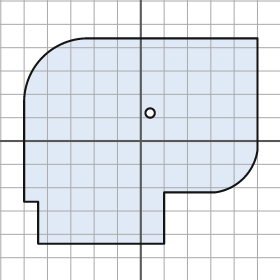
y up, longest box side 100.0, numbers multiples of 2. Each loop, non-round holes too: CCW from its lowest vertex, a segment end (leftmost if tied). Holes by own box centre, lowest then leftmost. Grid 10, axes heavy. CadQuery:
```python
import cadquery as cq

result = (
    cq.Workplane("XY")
    .moveTo(-44.0, -44.0)
    .lineTo(10.0, -44.0)
    .lineTo(10.0, -22.0)
    .lineTo(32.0, -22.0)
    .threePointArc((44.0, -16.0), (50.0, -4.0))
    .lineTo(50.0, 44.0)
    .lineTo(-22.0, 44.0)
    .threePointArc((-42.0, 36.0), (-50.0, 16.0))
    .lineTo(-50.0, -26.0)
    .lineTo(-44.0, -26.0)
    .close()
    .moveTo(4.0, 12.0)
    .circle(2.0)
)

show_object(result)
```